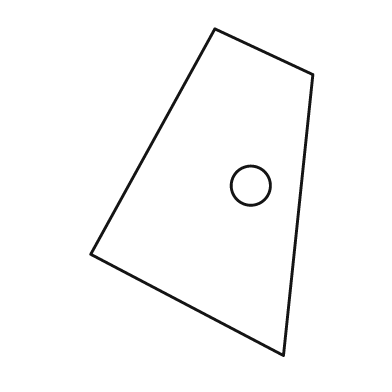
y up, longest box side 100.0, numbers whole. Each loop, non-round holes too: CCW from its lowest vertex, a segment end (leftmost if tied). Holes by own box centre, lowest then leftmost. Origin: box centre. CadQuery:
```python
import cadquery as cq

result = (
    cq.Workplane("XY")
    .moveTo(25.0, -50.0)
    .lineTo(34.0, 36.0)
    .lineTo(4.0, 50.0)
    .lineTo(-34.0, -19.0)
    .close()
    .moveTo(15.0, 2.0)
    .circle(6.0)
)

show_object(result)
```